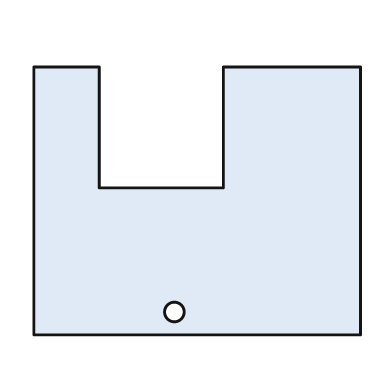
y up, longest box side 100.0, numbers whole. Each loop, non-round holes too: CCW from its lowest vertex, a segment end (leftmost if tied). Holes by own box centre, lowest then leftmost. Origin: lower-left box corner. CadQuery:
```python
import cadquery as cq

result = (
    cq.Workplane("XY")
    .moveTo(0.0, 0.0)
    .lineTo(100.0, 0.0)
    .lineTo(100.0, 82.0)
    .lineTo(58.0, 82.0)
    .lineTo(58.0, 45.0)
    .lineTo(20.0, 45.0)
    .lineTo(20.0, 82.0)
    .lineTo(0.0, 82.0)
    .close()
    .moveTo(43.0, 7.0)
    .circle(3.0)
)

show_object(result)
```